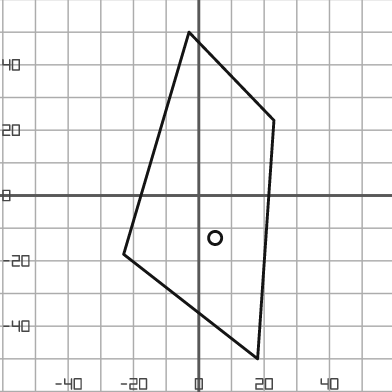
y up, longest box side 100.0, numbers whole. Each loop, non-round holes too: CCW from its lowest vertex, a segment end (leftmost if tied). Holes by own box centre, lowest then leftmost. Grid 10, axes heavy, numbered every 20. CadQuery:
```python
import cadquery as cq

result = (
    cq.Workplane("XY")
    .moveTo(18.0, -50.0)
    .lineTo(23.0, 23.0)
    .lineTo(-3.0, 50.0)
    .lineTo(-23.0, -18.0)
    .close()
    .moveTo(5.0, -13.0)
    .circle(2.0)
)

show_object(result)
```